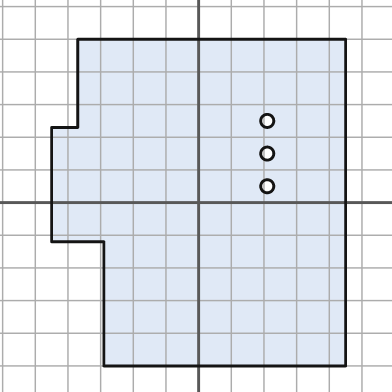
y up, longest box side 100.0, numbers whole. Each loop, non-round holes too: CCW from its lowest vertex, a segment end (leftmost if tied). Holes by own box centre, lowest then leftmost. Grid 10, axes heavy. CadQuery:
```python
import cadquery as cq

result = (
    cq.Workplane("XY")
    .moveTo(-29.0, -50.0)
    .lineTo(45.0, -50.0)
    .lineTo(45.0, 50.0)
    .lineTo(-37.0, 50.0)
    .lineTo(-37.0, 23.0)
    .lineTo(-45.0, 23.0)
    .lineTo(-45.0, -12.0)
    .lineTo(-29.0, -12.0)
    .close()
    .moveTo(21.0, 5.0)
    .circle(2.0)
    .moveTo(21.0, 15.0)
    .circle(2.0)
    .moveTo(21.0, 25.0)
    .circle(2.0)
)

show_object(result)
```